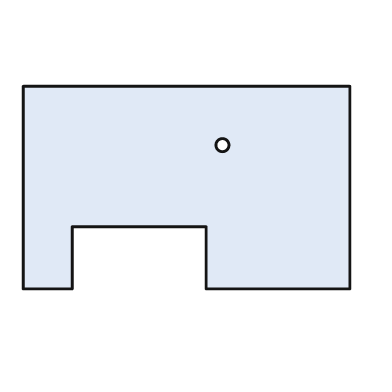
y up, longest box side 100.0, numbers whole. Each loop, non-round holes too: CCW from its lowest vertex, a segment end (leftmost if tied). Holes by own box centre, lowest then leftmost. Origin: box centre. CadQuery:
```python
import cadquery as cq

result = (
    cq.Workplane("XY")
    .moveTo(-50.0, -31.0)
    .lineTo(-35.0, -31.0)
    .lineTo(-35.0, -12.0)
    .lineTo(6.0, -12.0)
    .lineTo(6.0, -31.0)
    .lineTo(50.0, -31.0)
    .lineTo(50.0, 31.0)
    .lineTo(-50.0, 31.0)
    .close()
    .moveTo(11.0, 13.0)
    .circle(2.0)
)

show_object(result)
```